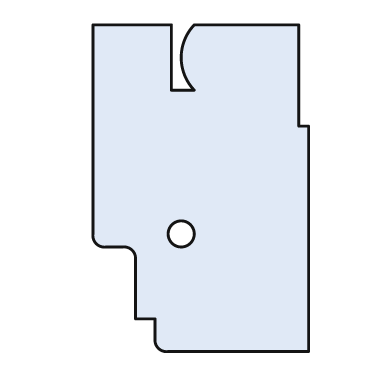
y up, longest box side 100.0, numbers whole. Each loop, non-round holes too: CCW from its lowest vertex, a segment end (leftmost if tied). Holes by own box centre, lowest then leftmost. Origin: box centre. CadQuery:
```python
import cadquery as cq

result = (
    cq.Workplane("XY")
    .moveTo(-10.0, -50.0)
    .lineTo(33.0, -50.0)
    .lineTo(33.0, 19.0)
    .lineTo(30.0, 19.0)
    .lineTo(30.0, 50.0)
    .lineTo(-2.0, 50.0)
    .threePointArc((-6.0, 40.0), (-2.0, 30.0))
    .lineTo(-9.0, 30.0)
    .lineTo(-9.0, 50.0)
    .lineTo(-33.0, 50.0)
    .lineTo(-33.0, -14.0)
    .threePointArc((-32.0, -17.0), (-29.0, -18.0))
    .lineTo(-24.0, -18.0)
    .threePointArc((-21.0, -19.0), (-20.0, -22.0))
    .lineTo(-20.0, -40.0)
    .lineTo(-14.0, -40.0)
    .lineTo(-14.0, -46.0)
    .threePointArc((-13.0, -49.0), (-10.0, -50.0))
    .close()
    .moveTo(-6.0, -14.0)
    .circle(4.0)
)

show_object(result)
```